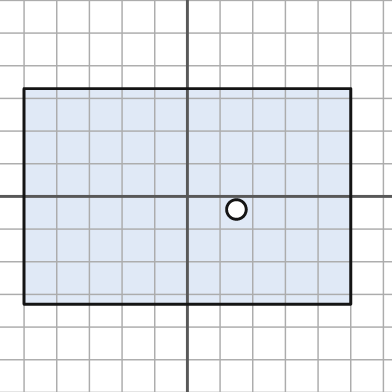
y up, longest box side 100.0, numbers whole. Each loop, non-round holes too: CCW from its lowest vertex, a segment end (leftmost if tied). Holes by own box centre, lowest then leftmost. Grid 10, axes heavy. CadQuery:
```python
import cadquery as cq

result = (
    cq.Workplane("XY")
    .moveTo(-50.0, -33.0)
    .lineTo(50.0, -33.0)
    .lineTo(50.0, 33.0)
    .lineTo(-50.0, 33.0)
    .close()
    .moveTo(15.0, -4.0)
    .circle(3.0)
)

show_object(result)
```